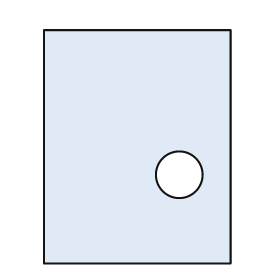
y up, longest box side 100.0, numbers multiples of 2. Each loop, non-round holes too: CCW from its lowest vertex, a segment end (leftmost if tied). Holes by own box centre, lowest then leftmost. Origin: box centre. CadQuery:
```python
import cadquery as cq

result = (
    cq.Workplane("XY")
    .moveTo(-40.0, -50.0)
    .lineTo(40.0, -50.0)
    .lineTo(40.0, 50.0)
    .lineTo(-40.0, 50.0)
    .close()
    .moveTo(18.0, -12.0)
    .circle(10.0)
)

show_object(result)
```